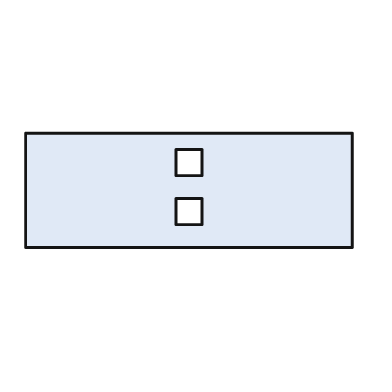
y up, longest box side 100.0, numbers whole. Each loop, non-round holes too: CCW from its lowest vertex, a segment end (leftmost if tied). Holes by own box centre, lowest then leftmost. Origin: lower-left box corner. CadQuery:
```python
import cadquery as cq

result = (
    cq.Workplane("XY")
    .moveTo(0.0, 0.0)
    .lineTo(100.0, 0.0)
    .lineTo(100.0, 35.0)
    .lineTo(0.0, 35.0)
    .close()
    .moveTo(46.0, 7.0)
    .lineTo(54.0, 7.0)
    .lineTo(54.0, 15.0)
    .lineTo(46.0, 15.0)
    .close()
    .moveTo(46.0, 22.0)
    .lineTo(54.0, 22.0)
    .lineTo(54.0, 30.0)
    .lineTo(46.0, 30.0)
    .close()
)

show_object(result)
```